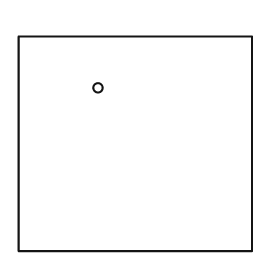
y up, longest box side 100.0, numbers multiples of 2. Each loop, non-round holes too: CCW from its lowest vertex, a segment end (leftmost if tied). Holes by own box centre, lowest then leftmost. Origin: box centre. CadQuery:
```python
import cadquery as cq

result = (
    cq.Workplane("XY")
    .moveTo(-50.0, -46.0)
    .lineTo(50.0, -46.0)
    .lineTo(50.0, 46.0)
    .lineTo(-50.0, 46.0)
    .close()
    .moveTo(-16.0, 24.0)
    .circle(2.0)
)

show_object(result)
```